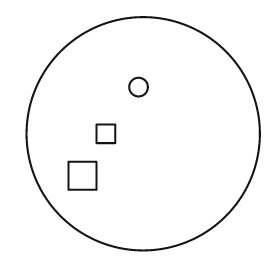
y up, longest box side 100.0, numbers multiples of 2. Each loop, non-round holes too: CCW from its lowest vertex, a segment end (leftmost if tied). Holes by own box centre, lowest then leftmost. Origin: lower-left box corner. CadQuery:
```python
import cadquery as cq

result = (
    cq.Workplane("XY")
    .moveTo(50.0, 50.0)
    .circle(50.0)
    .moveTo(18.0, 26.0)
    .lineTo(30.0, 26.0)
    .lineTo(30.0, 38.0)
    .lineTo(18.0, 38.0)
    .close()
    .moveTo(30.0, 46.0)
    .lineTo(38.0, 46.0)
    .lineTo(38.0, 54.0)
    .lineTo(30.0, 54.0)
    .close()
    .moveTo(48.0, 70.0)
    .circle(4.0)
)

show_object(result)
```